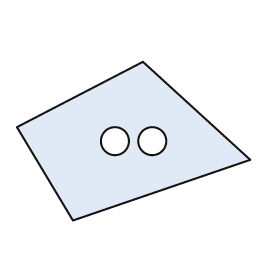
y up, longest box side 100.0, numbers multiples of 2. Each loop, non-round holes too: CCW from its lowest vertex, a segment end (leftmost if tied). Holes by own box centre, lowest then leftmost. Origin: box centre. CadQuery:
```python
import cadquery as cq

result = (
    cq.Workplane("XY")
    .moveTo(-26.0, -34.0)
    .lineTo(50.0, -8.0)
    .lineTo(4.0, 34.0)
    .lineTo(-50.0, 6.0)
    .close()
    .moveTo(-8.0, 0.0)
    .circle(6.0)
    .moveTo(8.0, 0.0)
    .circle(6.0)
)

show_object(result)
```